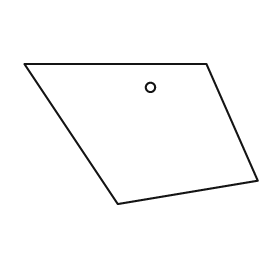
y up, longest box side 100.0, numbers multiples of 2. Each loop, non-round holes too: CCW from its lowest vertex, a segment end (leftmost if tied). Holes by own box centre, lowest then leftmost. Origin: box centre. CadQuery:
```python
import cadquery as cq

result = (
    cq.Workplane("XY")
    .moveTo(-10.0, -30.0)
    .lineTo(50.0, -20.0)
    .lineTo(28.0, 30.0)
    .lineTo(-50.0, 30.0)
    .close()
    .moveTo(4.0, 20.0)
    .circle(2.0)
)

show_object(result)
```